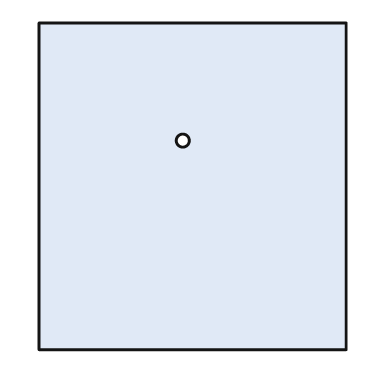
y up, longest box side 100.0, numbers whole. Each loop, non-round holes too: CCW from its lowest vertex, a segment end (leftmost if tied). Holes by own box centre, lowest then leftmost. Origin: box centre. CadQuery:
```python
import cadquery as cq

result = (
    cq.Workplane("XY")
    .moveTo(-47.0, -50.0)
    .lineTo(47.0, -50.0)
    .lineTo(47.0, 50.0)
    .lineTo(-47.0, 50.0)
    .close()
    .moveTo(-3.0, 14.0)
    .circle(2.0)
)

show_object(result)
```